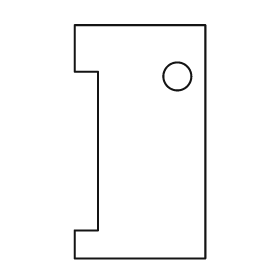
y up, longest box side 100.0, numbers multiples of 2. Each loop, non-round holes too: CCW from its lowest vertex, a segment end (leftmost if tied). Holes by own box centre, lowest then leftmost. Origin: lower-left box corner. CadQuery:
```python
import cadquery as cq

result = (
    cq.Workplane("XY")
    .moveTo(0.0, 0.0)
    .lineTo(56.0, 0.0)
    .lineTo(56.0, 100.0)
    .lineTo(0.0, 100.0)
    .lineTo(0.0, 80.0)
    .lineTo(10.0, 80.0)
    .lineTo(10.0, 12.0)
    .lineTo(0.0, 12.0)
    .close()
    .moveTo(44.0, 78.0)
    .circle(6.0)
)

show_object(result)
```